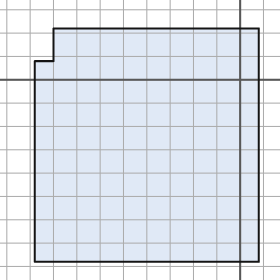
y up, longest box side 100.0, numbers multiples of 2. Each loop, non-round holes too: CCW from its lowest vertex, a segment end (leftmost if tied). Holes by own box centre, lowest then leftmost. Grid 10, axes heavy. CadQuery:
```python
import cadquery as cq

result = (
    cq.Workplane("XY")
    .moveTo(-88.0, -78.0)
    .lineTo(8.0, -78.0)
    .lineTo(8.0, 22.0)
    .lineTo(-80.0, 22.0)
    .lineTo(-80.0, 8.0)
    .lineTo(-88.0, 8.0)
    .close()
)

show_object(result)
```